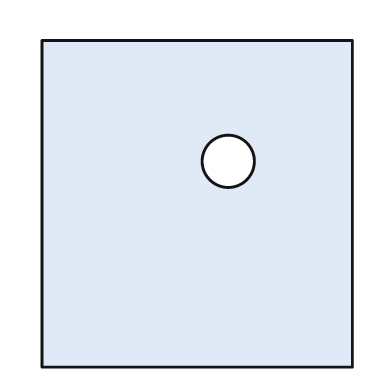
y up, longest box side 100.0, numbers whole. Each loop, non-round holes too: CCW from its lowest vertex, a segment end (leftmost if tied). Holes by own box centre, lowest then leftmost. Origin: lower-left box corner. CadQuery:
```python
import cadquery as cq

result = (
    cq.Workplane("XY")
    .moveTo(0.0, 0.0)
    .lineTo(95.0, 0.0)
    .lineTo(95.0, 100.0)
    .lineTo(0.0, 100.0)
    .close()
    .moveTo(57.0, 63.0)
    .circle(8.0)
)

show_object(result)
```